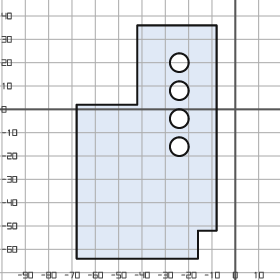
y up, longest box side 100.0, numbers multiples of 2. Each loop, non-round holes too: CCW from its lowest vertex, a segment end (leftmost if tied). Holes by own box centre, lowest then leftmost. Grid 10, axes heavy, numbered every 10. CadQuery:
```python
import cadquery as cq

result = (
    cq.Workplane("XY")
    .moveTo(-68.0, -64.0)
    .lineTo(-16.0, -64.0)
    .lineTo(-16.0, -52.0)
    .lineTo(-8.0, -52.0)
    .lineTo(-8.0, 36.0)
    .lineTo(-42.0, 36.0)
    .lineTo(-42.0, 2.0)
    .lineTo(-68.0, 2.0)
    .close()
    .moveTo(-24.0, -16.0)
    .circle(4.0)
    .moveTo(-24.0, -4.0)
    .circle(4.0)
    .moveTo(-24.0, 8.0)
    .circle(4.0)
    .moveTo(-24.0, 20.0)
    .circle(4.0)
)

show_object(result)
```